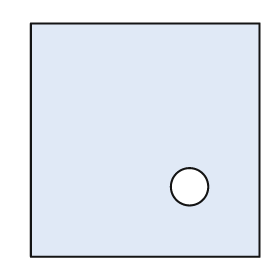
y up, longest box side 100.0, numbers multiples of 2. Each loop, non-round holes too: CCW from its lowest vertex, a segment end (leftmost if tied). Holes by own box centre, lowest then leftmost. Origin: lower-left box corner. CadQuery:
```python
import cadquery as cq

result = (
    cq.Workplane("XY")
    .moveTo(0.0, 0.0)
    .lineTo(98.0, 0.0)
    .lineTo(98.0, 100.0)
    .lineTo(0.0, 100.0)
    .close()
    .moveTo(68.0, 30.0)
    .circle(8.0)
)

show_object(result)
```